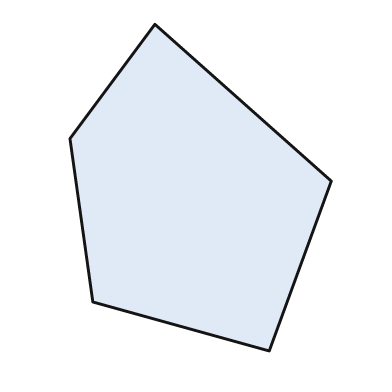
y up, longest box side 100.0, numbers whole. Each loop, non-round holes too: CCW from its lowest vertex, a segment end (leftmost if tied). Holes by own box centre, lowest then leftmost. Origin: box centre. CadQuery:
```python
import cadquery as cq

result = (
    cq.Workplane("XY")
    .moveTo(21.0, -50.0)
    .lineTo(40.0, 2.0)
    .lineTo(-14.0, 50.0)
    .lineTo(-40.0, 15.0)
    .lineTo(-33.0, -35.0)
    .close()
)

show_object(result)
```